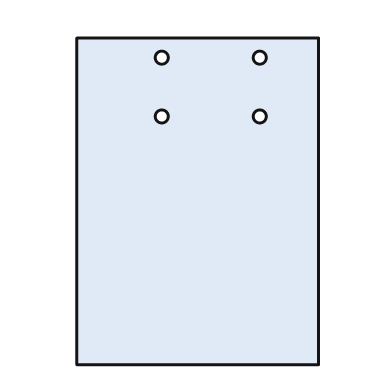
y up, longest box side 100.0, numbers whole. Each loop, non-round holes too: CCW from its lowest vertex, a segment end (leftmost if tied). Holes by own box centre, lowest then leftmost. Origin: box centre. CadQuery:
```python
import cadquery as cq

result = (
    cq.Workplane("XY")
    .moveTo(-37.0, -50.0)
    .lineTo(37.0, -50.0)
    .lineTo(37.0, 50.0)
    .lineTo(-37.0, 50.0)
    .close()
    .moveTo(-11.0, 26.0)
    .circle(2.0)
    .moveTo(19.0, 26.0)
    .circle(2.0)
    .moveTo(-11.0, 44.0)
    .circle(2.0)
    .moveTo(19.0, 44.0)
    .circle(2.0)
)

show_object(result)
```